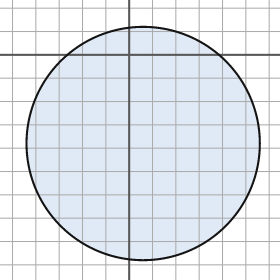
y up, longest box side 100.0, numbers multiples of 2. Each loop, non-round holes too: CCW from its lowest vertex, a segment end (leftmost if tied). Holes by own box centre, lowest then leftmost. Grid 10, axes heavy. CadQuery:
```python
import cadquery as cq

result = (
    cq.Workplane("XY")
    .moveTo(6.0, -38.0)
    .circle(50.0)
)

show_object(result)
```